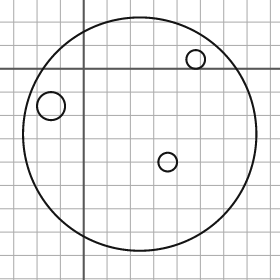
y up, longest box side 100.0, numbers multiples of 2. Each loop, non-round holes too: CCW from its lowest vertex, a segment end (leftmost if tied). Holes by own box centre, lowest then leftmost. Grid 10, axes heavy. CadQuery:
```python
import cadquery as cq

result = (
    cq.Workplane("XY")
    .moveTo(24.0, -28.0)
    .circle(50.0)
    .moveTo(36.0, -40.0)
    .circle(4.0)
    .moveTo(-14.0, -16.0)
    .circle(6.0)
    .moveTo(48.0, 4.0)
    .circle(4.0)
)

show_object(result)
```